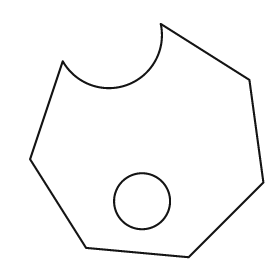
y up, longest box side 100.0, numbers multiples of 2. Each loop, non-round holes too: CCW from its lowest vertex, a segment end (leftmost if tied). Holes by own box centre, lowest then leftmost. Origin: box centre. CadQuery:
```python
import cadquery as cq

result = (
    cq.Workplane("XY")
    .moveTo(18.0, -50.0)
    .lineTo(50.0, -18.0)
    .lineTo(44.0, 26.0)
    .lineTo(6.0, 50.0)
    .threePointArc((-8.0, 24.0), (-36.0, 34.0))
    .lineTo(-50.0, -8.0)
    .lineTo(-26.0, -46.0)
    .close()
    .moveTo(-2.0, -26.0)
    .circle(12.0)
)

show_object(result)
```